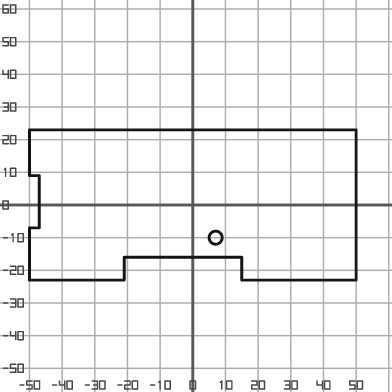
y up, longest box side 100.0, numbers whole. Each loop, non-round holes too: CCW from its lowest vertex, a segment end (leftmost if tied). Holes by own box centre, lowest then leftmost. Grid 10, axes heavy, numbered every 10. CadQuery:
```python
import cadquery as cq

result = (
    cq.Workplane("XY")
    .moveTo(-50.0, -23.0)
    .lineTo(-21.0, -23.0)
    .lineTo(-21.0, -16.0)
    .lineTo(15.0, -16.0)
    .lineTo(15.0, -23.0)
    .lineTo(50.0, -23.0)
    .lineTo(50.0, 23.0)
    .lineTo(-50.0, 23.0)
    .lineTo(-50.0, 9.0)
    .lineTo(-47.0, 9.0)
    .lineTo(-47.0, -7.0)
    .lineTo(-50.0, -7.0)
    .close()
    .moveTo(7.0, -10.0)
    .circle(2.0)
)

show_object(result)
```